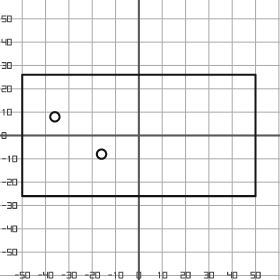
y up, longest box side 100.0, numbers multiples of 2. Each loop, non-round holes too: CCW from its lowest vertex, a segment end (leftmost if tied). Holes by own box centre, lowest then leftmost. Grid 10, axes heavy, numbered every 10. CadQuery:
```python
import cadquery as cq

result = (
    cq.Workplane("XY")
    .moveTo(-50.0, -26.0)
    .lineTo(50.0, -26.0)
    .lineTo(50.0, 26.0)
    .lineTo(-50.0, 26.0)
    .close()
    .moveTo(-16.0, -8.0)
    .circle(2.0)
    .moveTo(-36.0, 8.0)
    .circle(2.0)
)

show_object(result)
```